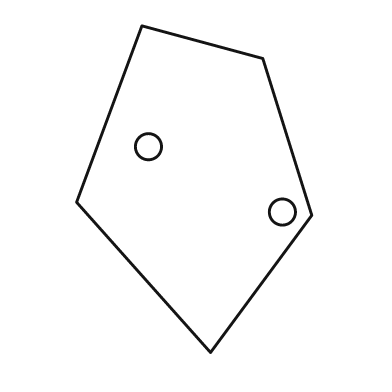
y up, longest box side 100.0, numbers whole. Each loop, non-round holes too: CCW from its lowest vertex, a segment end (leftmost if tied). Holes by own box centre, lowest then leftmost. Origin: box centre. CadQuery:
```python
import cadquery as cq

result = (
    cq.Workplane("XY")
    .moveTo(5.0, -50.0)
    .lineTo(36.0, -8.0)
    .lineTo(21.0, 40.0)
    .lineTo(-16.0, 50.0)
    .lineTo(-36.0, -4.0)
    .close()
    .moveTo(27.0, -7.0)
    .circle(4.0)
    .moveTo(-14.0, 13.0)
    .circle(4.0)
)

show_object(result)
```